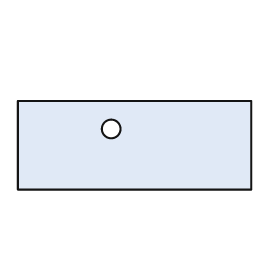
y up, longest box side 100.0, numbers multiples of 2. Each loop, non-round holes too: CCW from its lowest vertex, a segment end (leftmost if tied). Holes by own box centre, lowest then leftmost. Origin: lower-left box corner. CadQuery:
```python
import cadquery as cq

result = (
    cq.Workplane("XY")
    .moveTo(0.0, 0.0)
    .lineTo(100.0, 0.0)
    .lineTo(100.0, 38.0)
    .lineTo(0.0, 38.0)
    .close()
    .moveTo(40.0, 26.0)
    .circle(4.0)
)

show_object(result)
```